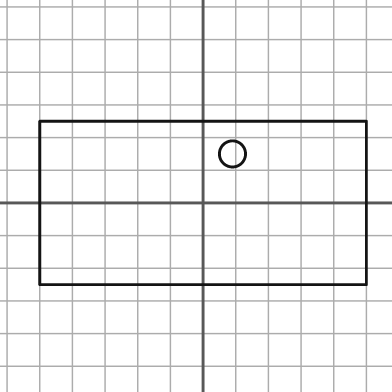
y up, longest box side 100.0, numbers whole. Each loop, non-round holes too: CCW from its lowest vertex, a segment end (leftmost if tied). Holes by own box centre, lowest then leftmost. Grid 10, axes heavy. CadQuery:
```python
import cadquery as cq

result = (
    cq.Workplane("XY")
    .moveTo(-50.0, -25.0)
    .lineTo(50.0, -25.0)
    .lineTo(50.0, 25.0)
    .lineTo(-50.0, 25.0)
    .close()
    .moveTo(9.0, 15.0)
    .circle(4.0)
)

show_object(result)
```